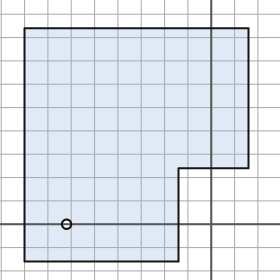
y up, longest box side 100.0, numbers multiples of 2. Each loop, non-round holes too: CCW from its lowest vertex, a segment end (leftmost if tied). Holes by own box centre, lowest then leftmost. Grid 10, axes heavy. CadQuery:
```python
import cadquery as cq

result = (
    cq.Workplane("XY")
    .moveTo(-80.0, -16.0)
    .lineTo(-14.0, -16.0)
    .lineTo(-14.0, 24.0)
    .lineTo(16.0, 24.0)
    .lineTo(16.0, 84.0)
    .lineTo(-80.0, 84.0)
    .close()
    .moveTo(-62.0, 0.0)
    .circle(2.0)
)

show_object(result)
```